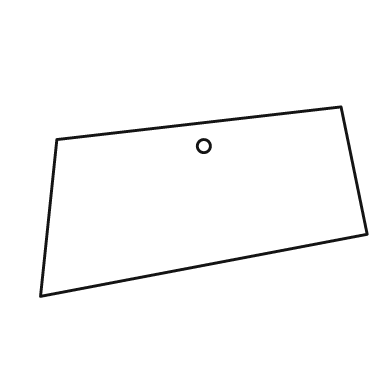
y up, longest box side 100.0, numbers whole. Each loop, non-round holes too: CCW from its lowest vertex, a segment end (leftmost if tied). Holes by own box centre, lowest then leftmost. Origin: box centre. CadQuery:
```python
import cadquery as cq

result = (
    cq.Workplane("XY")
    .moveTo(-50.0, -29.0)
    .lineTo(50.0, -10.0)
    .lineTo(42.0, 29.0)
    .lineTo(-45.0, 19.0)
    .close()
    .moveTo(0.0, 17.0)
    .circle(2.0)
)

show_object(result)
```